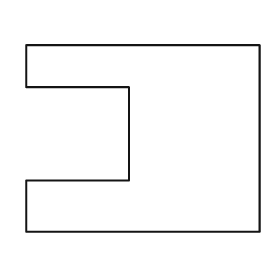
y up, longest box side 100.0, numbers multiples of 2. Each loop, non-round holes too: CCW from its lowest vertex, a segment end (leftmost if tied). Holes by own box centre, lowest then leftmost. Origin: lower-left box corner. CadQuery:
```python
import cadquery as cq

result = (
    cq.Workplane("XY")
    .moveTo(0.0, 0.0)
    .lineTo(100.0, 0.0)
    .lineTo(100.0, 80.0)
    .lineTo(0.0, 80.0)
    .lineTo(0.0, 62.0)
    .lineTo(44.0, 62.0)
    .lineTo(44.0, 22.0)
    .lineTo(0.0, 22.0)
    .close()
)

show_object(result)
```